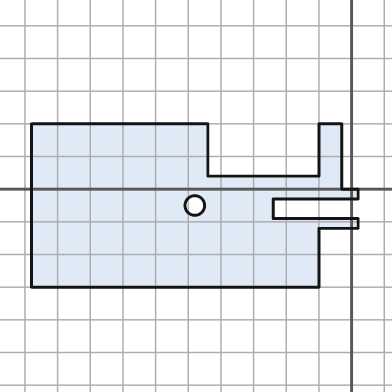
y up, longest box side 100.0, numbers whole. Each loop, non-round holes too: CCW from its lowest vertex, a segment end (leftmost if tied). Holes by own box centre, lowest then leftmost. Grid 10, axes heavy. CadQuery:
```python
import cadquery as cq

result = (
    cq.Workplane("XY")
    .moveTo(-98.0, -30.0)
    .lineTo(-10.0, -30.0)
    .lineTo(-10.0, -12.0)
    .lineTo(2.0, -12.0)
    .lineTo(2.0, -9.0)
    .lineTo(-24.0, -9.0)
    .lineTo(-24.0, -3.0)
    .lineTo(2.0, -3.0)
    .lineTo(2.0, 0.0)
    .lineTo(-3.0, 0.0)
    .lineTo(-3.0, 20.0)
    .lineTo(-10.0, 20.0)
    .lineTo(-10.0, 4.0)
    .lineTo(-44.0, 4.0)
    .lineTo(-44.0, 20.0)
    .lineTo(-98.0, 20.0)
    .close()
    .moveTo(-48.0, -5.0)
    .circle(3.0)
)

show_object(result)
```